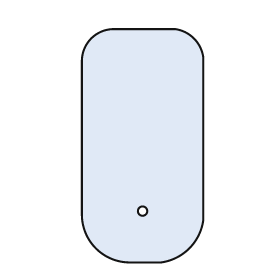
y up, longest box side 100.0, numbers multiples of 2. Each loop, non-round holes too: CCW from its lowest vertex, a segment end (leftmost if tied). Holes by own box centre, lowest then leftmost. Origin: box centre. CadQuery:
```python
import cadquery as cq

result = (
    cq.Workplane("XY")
    .moveTo(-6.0, -50.0)
    .lineTo(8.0, -50.0)
    .threePointArc((20.0, -44.0), (26.0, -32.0))
    .lineTo(26.0, 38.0)
    .threePointArc((22.0, 46.0), (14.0, 50.0))
    .lineTo(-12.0, 50.0)
    .threePointArc((-22.0, 46.0), (-26.0, 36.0))
    .lineTo(-26.0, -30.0)
    .threePointArc((-20.0, -44.0), (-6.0, -50.0))
    .close()
    .moveTo(0.0, -28.0)
    .circle(2.0)
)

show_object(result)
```